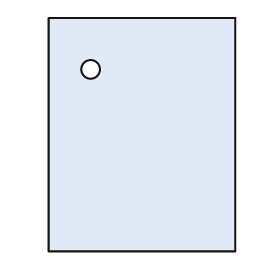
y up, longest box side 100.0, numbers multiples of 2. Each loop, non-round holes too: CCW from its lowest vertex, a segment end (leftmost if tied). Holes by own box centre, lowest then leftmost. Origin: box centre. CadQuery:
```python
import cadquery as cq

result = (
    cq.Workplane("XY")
    .moveTo(-40.0, -50.0)
    .lineTo(40.0, -50.0)
    .lineTo(40.0, 50.0)
    .lineTo(-40.0, 50.0)
    .close()
    .moveTo(-22.0, 28.0)
    .circle(4.0)
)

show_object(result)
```